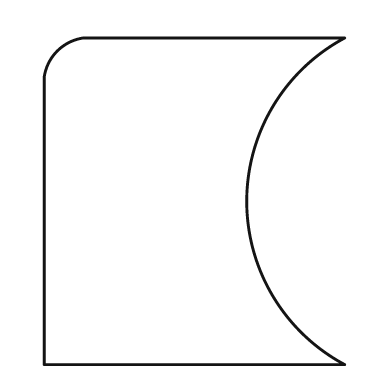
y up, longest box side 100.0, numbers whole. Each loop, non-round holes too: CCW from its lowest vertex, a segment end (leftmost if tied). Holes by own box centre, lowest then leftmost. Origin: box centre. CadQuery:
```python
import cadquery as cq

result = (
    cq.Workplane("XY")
    .moveTo(-46.0, -50.0)
    .lineTo(46.0, -50.0)
    .threePointArc((16.0, 0.0), (46.0, 50.0))
    .lineTo(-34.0, 50.0)
    .threePointArc((-42.0, 46.0), (-46.0, 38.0))
    .close()
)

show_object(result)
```